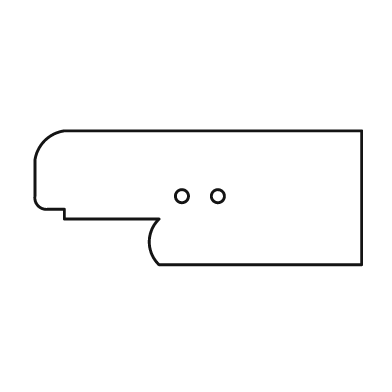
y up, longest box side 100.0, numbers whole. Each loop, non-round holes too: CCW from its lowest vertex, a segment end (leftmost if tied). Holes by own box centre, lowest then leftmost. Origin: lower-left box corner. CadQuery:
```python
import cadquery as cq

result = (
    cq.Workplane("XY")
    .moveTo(38.0, 0.0)
    .lineTo(100.0, 0.0)
    .lineTo(100.0, 41.0)
    .lineTo(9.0, 41.0)
    .threePointArc((3.0, 38.0), (0.0, 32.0))
    .lineTo(0.0, 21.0)
    .threePointArc((1.0, 18.0), (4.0, 17.0))
    .lineTo(9.0, 17.0)
    .lineTo(9.0, 14.0)
    .lineTo(38.0, 14.0)
    .threePointArc((35.0, 7.0), (38.0, 0.0))
    .close()
    .moveTo(45.0, 21.0)
    .circle(2.0)
    .moveTo(56.0, 21.0)
    .circle(2.0)
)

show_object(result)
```